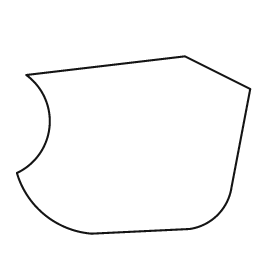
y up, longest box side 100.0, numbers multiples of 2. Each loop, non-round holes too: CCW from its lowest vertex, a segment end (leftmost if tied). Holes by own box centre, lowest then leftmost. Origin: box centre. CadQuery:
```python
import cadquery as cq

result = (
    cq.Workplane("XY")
    .moveTo(-18.0, -38.0)
    .lineTo(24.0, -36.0)
    .threePointArc((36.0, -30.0), (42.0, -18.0))
    .lineTo(50.0, 24.0)
    .lineTo(22.0, 38.0)
    .lineTo(-46.0, 30.0)
    .threePointArc((-36.0, 8.0), (-50.0, -12.0))
    .threePointArc((-38.0, -30.0), (-18.0, -38.0))
    .close()
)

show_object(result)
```